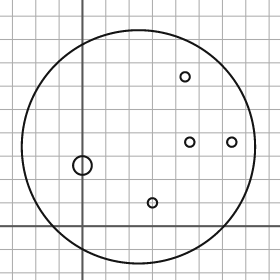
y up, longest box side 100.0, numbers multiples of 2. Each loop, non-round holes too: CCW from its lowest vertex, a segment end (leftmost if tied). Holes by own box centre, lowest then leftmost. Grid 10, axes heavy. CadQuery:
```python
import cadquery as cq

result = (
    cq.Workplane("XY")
    .moveTo(24.0, 34.0)
    .circle(50.0)
    .moveTo(30.0, 10.0)
    .circle(2.0)
    .moveTo(0.0, 26.0)
    .circle(4.0)
    .moveTo(46.0, 36.0)
    .circle(2.0)
    .moveTo(64.0, 36.0)
    .circle(2.0)
    .moveTo(44.0, 64.0)
    .circle(2.0)
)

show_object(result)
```